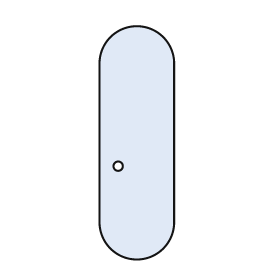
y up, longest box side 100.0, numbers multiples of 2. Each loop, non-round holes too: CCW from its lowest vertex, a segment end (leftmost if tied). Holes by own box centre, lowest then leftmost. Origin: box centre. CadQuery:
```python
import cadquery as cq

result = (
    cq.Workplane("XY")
    .moveTo(-16.0, -34.0)
    .threePointArc((0.0, -50.0), (16.0, -34.0))
    .lineTo(16.0, 34.0)
    .threePointArc((0.0, 50.0), (-16.0, 34.0))
    .close()
    .moveTo(-8.0, -10.0)
    .circle(2.0)
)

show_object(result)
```